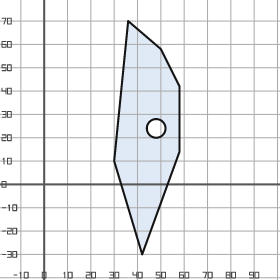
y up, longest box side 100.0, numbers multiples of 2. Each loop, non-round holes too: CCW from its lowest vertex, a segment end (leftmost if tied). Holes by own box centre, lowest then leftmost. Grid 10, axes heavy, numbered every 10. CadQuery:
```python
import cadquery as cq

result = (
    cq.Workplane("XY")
    .moveTo(42.0, -30.0)
    .lineTo(58.0, 14.0)
    .lineTo(58.0, 42.0)
    .lineTo(50.0, 58.0)
    .lineTo(36.0, 70.0)
    .lineTo(30.0, 10.0)
    .close()
    .moveTo(48.0, 24.0)
    .circle(4.0)
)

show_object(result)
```